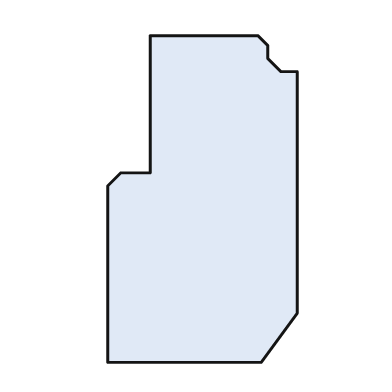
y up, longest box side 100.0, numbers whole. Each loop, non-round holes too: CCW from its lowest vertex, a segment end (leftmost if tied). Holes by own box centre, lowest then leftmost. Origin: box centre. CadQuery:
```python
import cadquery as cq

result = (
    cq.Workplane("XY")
    .moveTo(-29.0, -50.0)
    .lineTo(18.0, -50.0)
    .lineTo(29.0, -35.0)
    .lineTo(29.0, 39.0)
    .lineTo(24.0, 39.0)
    .lineTo(20.0, 43.0)
    .lineTo(20.0, 47.0)
    .lineTo(17.0, 50.0)
    .lineTo(-16.0, 50.0)
    .lineTo(-16.0, 8.0)
    .lineTo(-25.0, 8.0)
    .lineTo(-29.0, 4.0)
    .close()
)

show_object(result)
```